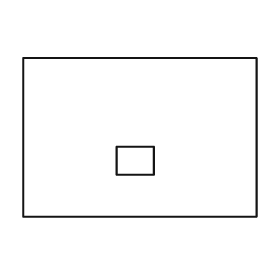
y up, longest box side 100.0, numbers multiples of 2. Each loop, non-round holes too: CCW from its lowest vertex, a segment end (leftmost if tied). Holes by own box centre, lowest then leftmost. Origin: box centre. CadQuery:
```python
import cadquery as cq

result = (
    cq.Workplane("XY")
    .moveTo(-50.0, -34.0)
    .lineTo(50.0, -34.0)
    .lineTo(50.0, 34.0)
    .lineTo(-50.0, 34.0)
    .close()
    .moveTo(-10.0, -16.0)
    .lineTo(6.0, -16.0)
    .lineTo(6.0, -4.0)
    .lineTo(-10.0, -4.0)
    .close()
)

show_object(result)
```